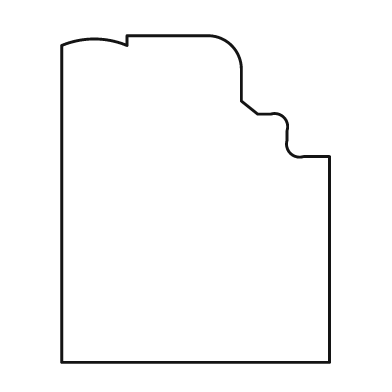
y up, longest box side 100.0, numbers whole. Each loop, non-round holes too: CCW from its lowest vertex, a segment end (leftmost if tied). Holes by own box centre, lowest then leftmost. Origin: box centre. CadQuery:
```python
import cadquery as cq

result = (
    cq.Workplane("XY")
    .moveTo(-41.0, -50.0)
    .lineTo(41.0, -50.0)
    .lineTo(41.0, 13.0)
    .lineTo(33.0, 13.0)
    .threePointArc((29.0, 14.0), (28.0, 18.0))
    .lineTo(28.0, 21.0)
    .threePointArc((27.0, 25.0), (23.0, 26.0))
    .lineTo(19.0, 26.0)
    .lineTo(14.0, 30.0)
    .lineTo(14.0, 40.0)
    .threePointArc((11.0, 47.0), (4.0, 50.0))
    .lineTo(-21.0, 50.0)
    .lineTo(-21.0, 47.0)
    .threePointArc((-31.0, 49.0), (-41.0, 47.0))
    .close()
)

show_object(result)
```